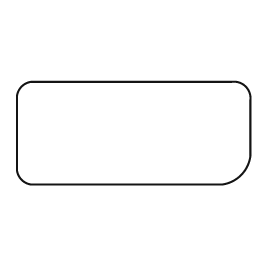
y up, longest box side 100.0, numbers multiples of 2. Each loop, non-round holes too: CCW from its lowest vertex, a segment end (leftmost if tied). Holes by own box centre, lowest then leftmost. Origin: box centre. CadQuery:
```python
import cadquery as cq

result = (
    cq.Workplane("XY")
    .moveTo(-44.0, -22.0)
    .lineTo(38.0, -22.0)
    .threePointArc((46.0, -18.0), (50.0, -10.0))
    .lineTo(50.0, 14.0)
    .threePointArc((48.0, 20.0), (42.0, 22.0))
    .lineTo(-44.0, 22.0)
    .threePointArc((-48.0, 20.0), (-50.0, 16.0))
    .lineTo(-50.0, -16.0)
    .threePointArc((-48.0, -20.0), (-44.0, -22.0))
    .close()
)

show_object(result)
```